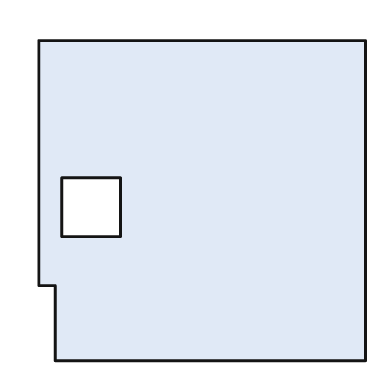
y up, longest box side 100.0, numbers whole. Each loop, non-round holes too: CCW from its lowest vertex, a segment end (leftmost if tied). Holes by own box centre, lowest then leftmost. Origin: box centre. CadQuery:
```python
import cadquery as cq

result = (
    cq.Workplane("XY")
    .moveTo(-45.0, -49.0)
    .lineTo(50.0, -49.0)
    .lineTo(50.0, 49.0)
    .lineTo(-50.0, 49.0)
    .lineTo(-50.0, -26.0)
    .lineTo(-45.0, -26.0)
    .close()
    .moveTo(-43.0, -11.0)
    .lineTo(-25.0, -11.0)
    .lineTo(-25.0, 7.0)
    .lineTo(-43.0, 7.0)
    .close()
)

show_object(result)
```